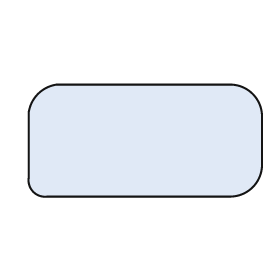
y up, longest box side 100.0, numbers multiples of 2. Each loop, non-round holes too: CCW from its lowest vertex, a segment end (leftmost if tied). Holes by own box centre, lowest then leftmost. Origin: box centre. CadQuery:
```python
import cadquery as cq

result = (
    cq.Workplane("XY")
    .moveTo(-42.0, -24.0)
    .lineTo(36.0, -24.0)
    .threePointArc((46.0, -20.0), (50.0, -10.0))
    .lineTo(50.0, 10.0)
    .threePointArc((46.0, 20.0), (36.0, 24.0))
    .lineTo(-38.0, 24.0)
    .threePointArc((-46.0, 20.0), (-50.0, 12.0))
    .lineTo(-50.0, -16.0)
    .threePointArc((-48.0, -22.0), (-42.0, -24.0))
    .close()
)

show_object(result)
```